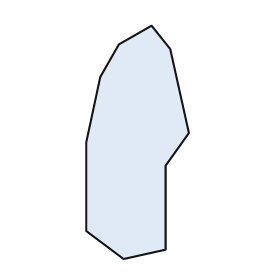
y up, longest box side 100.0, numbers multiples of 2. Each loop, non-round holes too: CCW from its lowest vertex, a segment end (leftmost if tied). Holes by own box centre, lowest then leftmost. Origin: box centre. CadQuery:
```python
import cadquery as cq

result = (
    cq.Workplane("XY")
    .moveTo(-6.0, -50.0)
    .lineTo(12.0, -46.0)
    .lineTo(12.0, -10.0)
    .lineTo(22.0, 4.0)
    .lineTo(14.0, 40.0)
    .lineTo(6.0, 50.0)
    .lineTo(-8.0, 42.0)
    .lineTo(-16.0, 28.0)
    .lineTo(-22.0, 0.0)
    .lineTo(-22.0, -38.0)
    .close()
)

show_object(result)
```